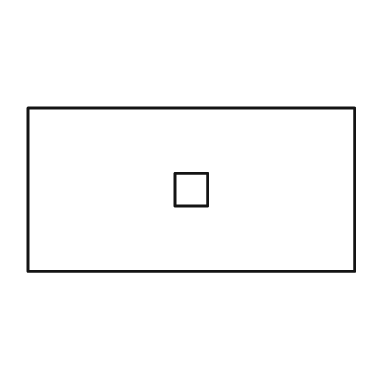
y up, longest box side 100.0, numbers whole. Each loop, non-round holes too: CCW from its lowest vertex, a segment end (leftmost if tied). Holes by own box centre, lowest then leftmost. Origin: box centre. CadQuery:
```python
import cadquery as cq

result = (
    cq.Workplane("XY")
    .moveTo(-50.0, -25.0)
    .lineTo(50.0, -25.0)
    .lineTo(50.0, 25.0)
    .lineTo(-50.0, 25.0)
    .close()
    .moveTo(-5.0, -5.0)
    .lineTo(5.0, -5.0)
    .lineTo(5.0, 5.0)
    .lineTo(-5.0, 5.0)
    .close()
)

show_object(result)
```